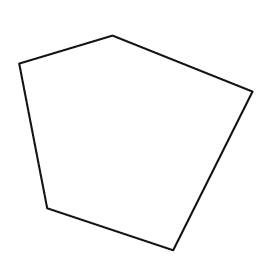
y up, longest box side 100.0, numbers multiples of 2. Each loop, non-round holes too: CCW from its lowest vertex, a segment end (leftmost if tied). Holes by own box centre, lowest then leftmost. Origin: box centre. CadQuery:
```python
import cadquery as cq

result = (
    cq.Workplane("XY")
    .moveTo(16.0, -46.0)
    .lineTo(50.0, 22.0)
    .lineTo(-10.0, 46.0)
    .lineTo(-50.0, 34.0)
    .lineTo(-38.0, -28.0)
    .close()
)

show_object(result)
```